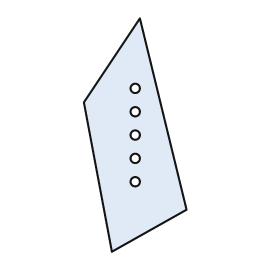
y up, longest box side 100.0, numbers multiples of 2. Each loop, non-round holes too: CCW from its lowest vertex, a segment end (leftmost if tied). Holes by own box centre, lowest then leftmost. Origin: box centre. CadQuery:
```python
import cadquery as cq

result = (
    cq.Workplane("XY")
    .moveTo(-10.0, -50.0)
    .lineTo(22.0, -32.0)
    .lineTo(2.0, 50.0)
    .lineTo(-22.0, 14.0)
    .close()
    .moveTo(0.0, -20.0)
    .circle(2.0)
    .moveTo(0.0, -10.0)
    .circle(2.0)
    .moveTo(0.0, 0.0)
    .circle(2.0)
    .moveTo(0.0, 10.0)
    .circle(2.0)
    .moveTo(0.0, 20.0)
    .circle(2.0)
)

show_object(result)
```